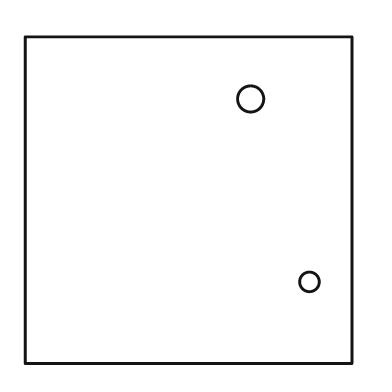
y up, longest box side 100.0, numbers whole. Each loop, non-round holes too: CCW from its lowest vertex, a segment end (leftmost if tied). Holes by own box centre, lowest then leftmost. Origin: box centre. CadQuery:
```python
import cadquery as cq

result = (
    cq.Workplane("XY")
    .moveTo(-50.0, -50.0)
    .lineTo(50.0, -50.0)
    .lineTo(50.0, 50.0)
    .lineTo(-50.0, 50.0)
    .close()
    .moveTo(37.0, -25.0)
    .circle(3.0)
    .moveTo(19.0, 31.0)
    .circle(4.0)
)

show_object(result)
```